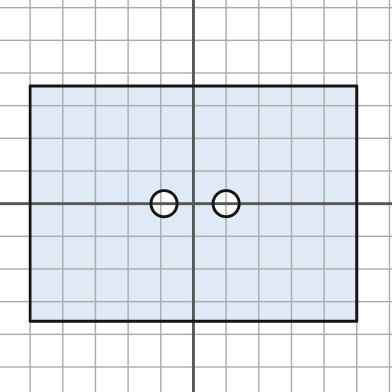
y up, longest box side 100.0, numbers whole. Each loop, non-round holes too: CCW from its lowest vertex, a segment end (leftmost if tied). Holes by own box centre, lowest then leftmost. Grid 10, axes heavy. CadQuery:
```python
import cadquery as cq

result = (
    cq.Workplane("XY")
    .moveTo(-50.0, -36.0)
    .lineTo(50.0, -36.0)
    .lineTo(50.0, 36.0)
    .lineTo(-50.0, 36.0)
    .close()
    .moveTo(-9.0, 0.0)
    .circle(4.0)
    .moveTo(10.0, 0.0)
    .circle(4.0)
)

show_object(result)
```